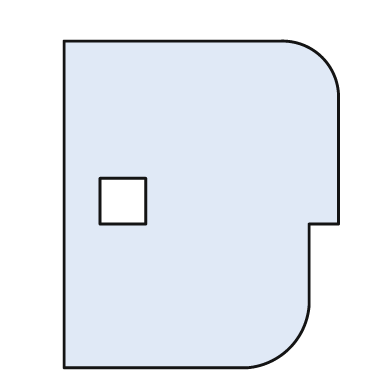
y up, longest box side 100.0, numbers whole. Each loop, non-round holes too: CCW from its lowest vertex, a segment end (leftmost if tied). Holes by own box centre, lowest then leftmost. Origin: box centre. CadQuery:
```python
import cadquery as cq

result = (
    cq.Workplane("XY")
    .moveTo(-42.0, -50.0)
    .lineTo(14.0, -50.0)
    .threePointArc((27.0, -44.0), (33.0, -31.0))
    .lineTo(33.0, -6.0)
    .lineTo(42.0, -6.0)
    .lineTo(42.0, 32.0)
    .threePointArc((37.0, 45.0), (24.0, 50.0))
    .lineTo(-42.0, 50.0)
    .close()
    .moveTo(-31.0, -6.0)
    .lineTo(-17.0, -6.0)
    .lineTo(-17.0, 8.0)
    .lineTo(-31.0, 8.0)
    .close()
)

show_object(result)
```